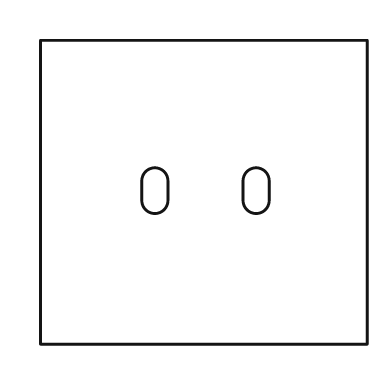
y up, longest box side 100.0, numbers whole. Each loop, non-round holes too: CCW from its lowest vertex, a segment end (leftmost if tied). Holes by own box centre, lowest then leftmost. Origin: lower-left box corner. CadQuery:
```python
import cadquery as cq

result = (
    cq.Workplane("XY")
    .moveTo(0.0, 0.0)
    .lineTo(100.0, 0.0)
    .lineTo(100.0, 93.0)
    .lineTo(0.0, 93.0)
    .close()
    .moveTo(31.0, 44.0)
    .threePointArc((35.0, 40.0), (39.0, 44.0))
    .lineTo(39.0, 50.0)
    .threePointArc((35.0, 54.0), (31.0, 50.0))
    .close()
    .moveTo(62.0, 44.0)
    .threePointArc((66.0, 40.0), (70.0, 44.0))
    .lineTo(70.0, 50.0)
    .threePointArc((66.0, 54.0), (62.0, 50.0))
    .close()
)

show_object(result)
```